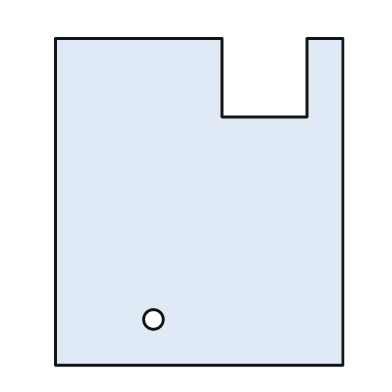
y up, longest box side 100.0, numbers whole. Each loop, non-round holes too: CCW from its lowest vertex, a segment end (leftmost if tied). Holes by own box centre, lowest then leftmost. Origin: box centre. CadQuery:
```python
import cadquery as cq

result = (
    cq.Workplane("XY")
    .moveTo(-44.0, -50.0)
    .lineTo(44.0, -50.0)
    .lineTo(44.0, 50.0)
    .lineTo(33.0, 50.0)
    .lineTo(33.0, 26.0)
    .lineTo(7.0, 26.0)
    .lineTo(7.0, 50.0)
    .lineTo(-44.0, 50.0)
    .close()
    .moveTo(-14.0, -36.0)
    .circle(3.0)
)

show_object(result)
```